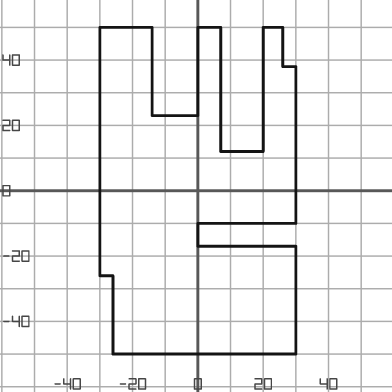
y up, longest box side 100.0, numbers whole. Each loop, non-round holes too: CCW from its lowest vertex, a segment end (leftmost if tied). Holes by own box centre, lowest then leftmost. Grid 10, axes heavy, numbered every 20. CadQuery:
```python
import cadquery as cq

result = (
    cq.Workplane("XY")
    .moveTo(-26.0, -50.0)
    .lineTo(30.0, -50.0)
    .lineTo(30.0, -17.0)
    .lineTo(0.0, -17.0)
    .lineTo(0.0, -10.0)
    .lineTo(30.0, -10.0)
    .lineTo(30.0, 38.0)
    .lineTo(26.0, 38.0)
    .lineTo(26.0, 50.0)
    .lineTo(20.0, 50.0)
    .lineTo(20.0, 12.0)
    .lineTo(7.0, 12.0)
    .lineTo(7.0, 50.0)
    .lineTo(0.0, 50.0)
    .lineTo(0.0, 23.0)
    .lineTo(-14.0, 23.0)
    .lineTo(-14.0, 50.0)
    .lineTo(-30.0, 50.0)
    .lineTo(-30.0, -26.0)
    .lineTo(-26.0, -26.0)
    .close()
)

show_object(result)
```